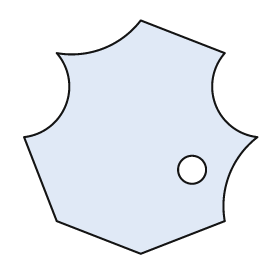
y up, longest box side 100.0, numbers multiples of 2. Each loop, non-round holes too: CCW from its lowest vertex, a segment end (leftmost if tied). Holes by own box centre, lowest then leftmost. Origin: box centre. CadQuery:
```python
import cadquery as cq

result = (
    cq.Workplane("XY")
    .moveTo(0.0, -50.0)
    .lineTo(36.0, -36.0)
    .threePointArc((38.0, -16.0), (50.0, 0.0))
    .threePointArc((32.0, 14.0), (36.0, 36.0))
    .lineTo(0.0, 50.0)
    .threePointArc((-16.0, 38.0), (-36.0, 36.0))
    .threePointArc((-32.0, 14.0), (-50.0, 0.0))
    .lineTo(-36.0, -36.0)
    .close()
    .moveTo(22.0, -14.0)
    .circle(6.0)
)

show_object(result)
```